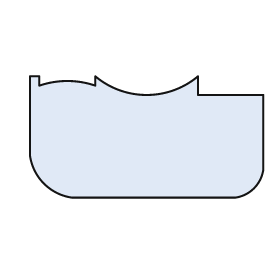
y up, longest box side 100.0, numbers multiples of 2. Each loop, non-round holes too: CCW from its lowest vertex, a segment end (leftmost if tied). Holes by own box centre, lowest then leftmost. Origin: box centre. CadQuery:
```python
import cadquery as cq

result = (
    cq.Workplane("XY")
    .moveTo(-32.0, -26.0)
    .lineTo(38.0, -26.0)
    .threePointArc((46.0, -22.0), (50.0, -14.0))
    .lineTo(50.0, 18.0)
    .lineTo(22.0, 18.0)
    .lineTo(22.0, 26.0)
    .threePointArc((0.0, 18.0), (-22.0, 26.0))
    .lineTo(-22.0, 22.0)
    .threePointArc((-34.0, 24.0), (-46.0, 22.0))
    .lineTo(-46.0, 26.0)
    .lineTo(-50.0, 26.0)
    .lineTo(-50.0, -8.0)
    .threePointArc((-44.0, -20.0), (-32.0, -26.0))
    .close()
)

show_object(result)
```